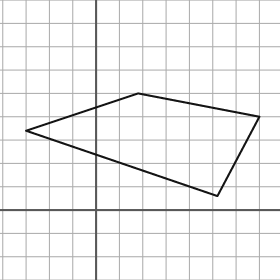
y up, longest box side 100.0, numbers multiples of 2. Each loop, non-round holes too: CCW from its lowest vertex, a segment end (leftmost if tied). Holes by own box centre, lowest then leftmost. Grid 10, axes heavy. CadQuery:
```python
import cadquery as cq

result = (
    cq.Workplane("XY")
    .moveTo(52.0, 6.0)
    .lineTo(70.0, 40.0)
    .lineTo(18.0, 50.0)
    .lineTo(-30.0, 34.0)
    .close()
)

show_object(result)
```